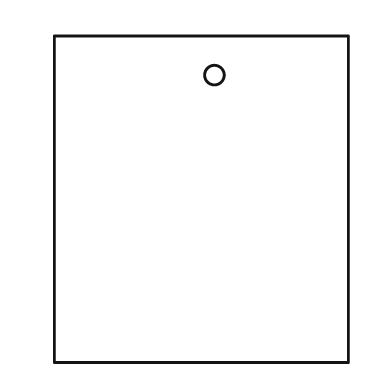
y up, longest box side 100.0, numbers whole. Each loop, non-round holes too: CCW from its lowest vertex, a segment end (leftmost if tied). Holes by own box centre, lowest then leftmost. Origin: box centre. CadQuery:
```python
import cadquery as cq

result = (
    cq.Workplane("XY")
    .moveTo(-45.0, -50.0)
    .lineTo(45.0, -50.0)
    .lineTo(45.0, 50.0)
    .lineTo(-45.0, 50.0)
    .close()
    .moveTo(4.0, 38.0)
    .circle(3.0)
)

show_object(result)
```